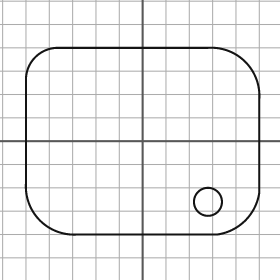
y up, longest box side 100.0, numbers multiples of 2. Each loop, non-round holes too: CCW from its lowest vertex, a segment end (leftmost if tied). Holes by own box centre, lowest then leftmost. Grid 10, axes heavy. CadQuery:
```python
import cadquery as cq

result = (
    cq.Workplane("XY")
    .moveTo(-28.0, -40.0)
    .lineTo(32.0, -40.0)
    .threePointArc((44.0, -34.0), (50.0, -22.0))
    .lineTo(50.0, 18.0)
    .threePointArc((44.0, 34.0), (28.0, 40.0))
    .lineTo(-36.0, 40.0)
    .threePointArc((-46.0, 36.0), (-50.0, 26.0))
    .lineTo(-50.0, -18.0)
    .threePointArc((-44.0, -34.0), (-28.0, -40.0))
    .close()
    .moveTo(28.0, -26.0)
    .circle(6.0)
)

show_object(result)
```